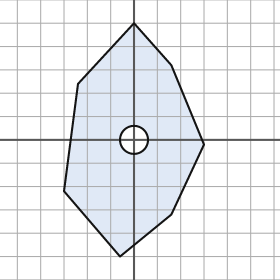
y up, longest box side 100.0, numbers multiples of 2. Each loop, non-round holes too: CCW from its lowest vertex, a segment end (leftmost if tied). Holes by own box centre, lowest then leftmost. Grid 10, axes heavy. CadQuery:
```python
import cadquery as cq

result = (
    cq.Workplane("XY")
    .moveTo(-6.0, -50.0)
    .lineTo(16.0, -32.0)
    .lineTo(30.0, -2.0)
    .lineTo(16.0, 32.0)
    .lineTo(0.0, 50.0)
    .lineTo(-24.0, 24.0)
    .lineTo(-30.0, -22.0)
    .close()
    .moveTo(0.0, 0.0)
    .circle(6.0)
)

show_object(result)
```